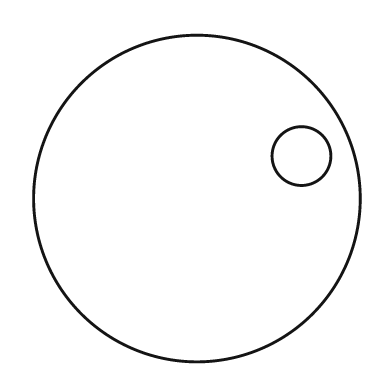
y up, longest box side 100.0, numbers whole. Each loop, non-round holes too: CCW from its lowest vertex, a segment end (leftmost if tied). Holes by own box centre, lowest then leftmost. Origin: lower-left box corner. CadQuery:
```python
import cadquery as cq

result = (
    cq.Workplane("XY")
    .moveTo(50.0, 50.0)
    .circle(50.0)
    .moveTo(82.0, 63.0)
    .circle(9.0)
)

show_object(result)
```